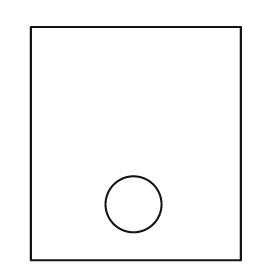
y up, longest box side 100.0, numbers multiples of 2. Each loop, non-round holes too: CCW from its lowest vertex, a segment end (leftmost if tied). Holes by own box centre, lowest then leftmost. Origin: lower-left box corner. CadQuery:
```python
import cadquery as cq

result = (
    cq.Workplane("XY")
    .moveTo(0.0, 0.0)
    .lineTo(90.0, 0.0)
    .lineTo(90.0, 100.0)
    .lineTo(0.0, 100.0)
    .close()
    .moveTo(44.0, 24.0)
    .circle(12.0)
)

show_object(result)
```